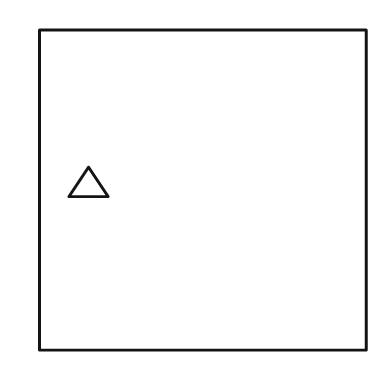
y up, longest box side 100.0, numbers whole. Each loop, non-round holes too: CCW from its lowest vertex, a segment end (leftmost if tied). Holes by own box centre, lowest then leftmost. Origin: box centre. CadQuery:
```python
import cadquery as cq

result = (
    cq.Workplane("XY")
    .moveTo(-50.0, -49.0)
    .lineTo(50.0, -49.0)
    .lineTo(50.0, 49.0)
    .lineTo(-50.0, 49.0)
    .close()
    .moveTo(-41.0, -2.0)
    .lineTo(-29.0, -2.0)
    .lineTo(-35.0, 7.0)
    .close()
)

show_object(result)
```